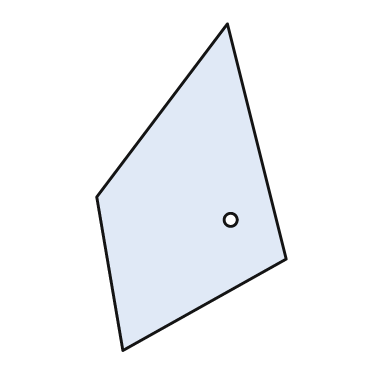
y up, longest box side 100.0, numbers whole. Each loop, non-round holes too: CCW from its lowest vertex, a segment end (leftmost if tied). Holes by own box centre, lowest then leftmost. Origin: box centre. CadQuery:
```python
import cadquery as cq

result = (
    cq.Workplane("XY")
    .moveTo(-21.0, -50.0)
    .lineTo(29.0, -22.0)
    .lineTo(11.0, 50.0)
    .lineTo(-29.0, -3.0)
    .close()
    .moveTo(12.0, -10.0)
    .circle(2.0)
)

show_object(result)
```